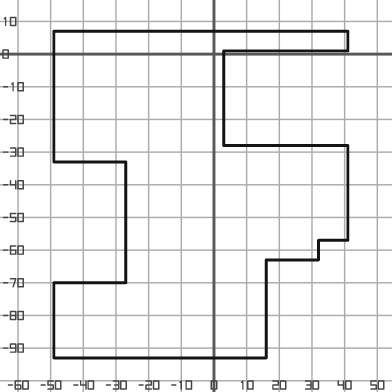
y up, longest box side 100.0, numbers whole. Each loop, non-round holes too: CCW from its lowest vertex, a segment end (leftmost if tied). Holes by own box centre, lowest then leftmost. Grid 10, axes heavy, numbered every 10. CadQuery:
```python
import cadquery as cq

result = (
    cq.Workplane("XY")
    .moveTo(-49.0, -93.0)
    .lineTo(16.0, -93.0)
    .lineTo(16.0, -63.0)
    .lineTo(32.0, -63.0)
    .lineTo(32.0, -57.0)
    .lineTo(41.0, -57.0)
    .lineTo(41.0, -28.0)
    .lineTo(3.0, -28.0)
    .lineTo(3.0, 1.0)
    .lineTo(41.0, 1.0)
    .lineTo(41.0, 7.0)
    .lineTo(-49.0, 7.0)
    .lineTo(-49.0, -33.0)
    .lineTo(-27.0, -33.0)
    .lineTo(-27.0, -70.0)
    .lineTo(-49.0, -70.0)
    .close()
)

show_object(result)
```